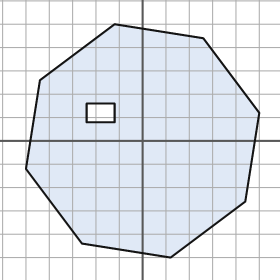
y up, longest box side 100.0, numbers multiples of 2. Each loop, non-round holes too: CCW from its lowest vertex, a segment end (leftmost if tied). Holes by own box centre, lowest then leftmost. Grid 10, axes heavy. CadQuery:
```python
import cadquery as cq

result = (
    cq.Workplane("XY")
    .moveTo(12.0, -50.0)
    .lineTo(44.0, -26.0)
    .lineTo(50.0, 12.0)
    .lineTo(26.0, 44.0)
    .lineTo(-12.0, 50.0)
    .lineTo(-44.0, 26.0)
    .lineTo(-50.0, -12.0)
    .lineTo(-26.0, -44.0)
    .close()
    .moveTo(-24.0, 8.0)
    .lineTo(-12.0, 8.0)
    .lineTo(-12.0, 16.0)
    .lineTo(-24.0, 16.0)
    .close()
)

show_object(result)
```